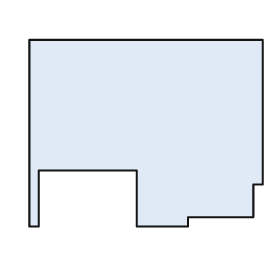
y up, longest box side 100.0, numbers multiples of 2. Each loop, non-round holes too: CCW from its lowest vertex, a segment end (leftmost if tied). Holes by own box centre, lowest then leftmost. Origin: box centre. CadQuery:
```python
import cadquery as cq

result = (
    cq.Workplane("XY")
    .moveTo(-50.0, -40.0)
    .lineTo(-46.0, -40.0)
    .lineTo(-46.0, -16.0)
    .lineTo(-4.0, -16.0)
    .lineTo(-4.0, -40.0)
    .lineTo(18.0, -40.0)
    .lineTo(18.0, -36.0)
    .lineTo(46.0, -36.0)
    .lineTo(46.0, -22.0)
    .lineTo(50.0, -22.0)
    .lineTo(50.0, 40.0)
    .lineTo(-50.0, 40.0)
    .close()
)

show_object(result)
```